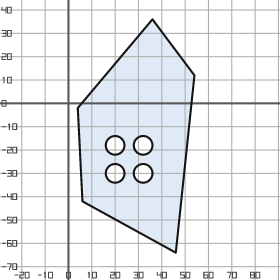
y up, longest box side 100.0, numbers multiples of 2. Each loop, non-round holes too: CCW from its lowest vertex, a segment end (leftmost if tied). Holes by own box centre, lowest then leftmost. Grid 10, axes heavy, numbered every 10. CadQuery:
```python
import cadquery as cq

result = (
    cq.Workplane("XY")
    .moveTo(46.0, -64.0)
    .lineTo(54.0, 12.0)
    .lineTo(36.0, 36.0)
    .lineTo(4.0, -2.0)
    .lineTo(6.0, -42.0)
    .close()
    .moveTo(20.0, -30.0)
    .circle(4.0)
    .moveTo(32.0, -30.0)
    .circle(4.0)
    .moveTo(20.0, -18.0)
    .circle(4.0)
    .moveTo(32.0, -18.0)
    .circle(4.0)
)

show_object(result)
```